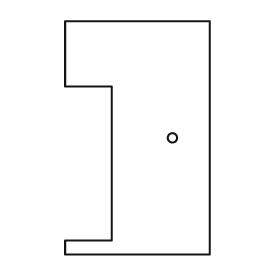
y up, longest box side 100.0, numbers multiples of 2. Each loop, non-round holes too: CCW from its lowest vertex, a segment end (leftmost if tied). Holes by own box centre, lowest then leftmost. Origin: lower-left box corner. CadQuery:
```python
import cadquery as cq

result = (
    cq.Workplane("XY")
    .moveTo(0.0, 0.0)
    .lineTo(62.0, 0.0)
    .lineTo(62.0, 100.0)
    .lineTo(0.0, 100.0)
    .lineTo(0.0, 72.0)
    .lineTo(20.0, 72.0)
    .lineTo(20.0, 6.0)
    .lineTo(0.0, 6.0)
    .close()
    .moveTo(46.0, 50.0)
    .circle(2.0)
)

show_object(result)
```